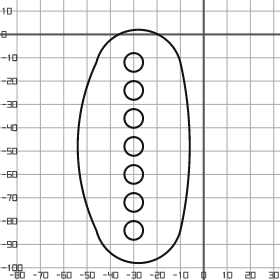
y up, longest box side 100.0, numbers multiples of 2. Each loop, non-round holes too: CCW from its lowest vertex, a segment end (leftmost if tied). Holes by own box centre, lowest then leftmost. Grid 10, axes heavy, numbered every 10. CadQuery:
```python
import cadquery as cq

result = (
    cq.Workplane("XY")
    .moveTo(-46.0, -84.0)
    .threePointArc((-28.0, -98.0), (-10.0, -84.0))
    .threePointArc((-6.0, -48.0), (-10.0, -12.0))
    .threePointArc((-28.0, 2.0), (-46.0, -12.0))
    .threePointArc((-54.0, -48.0), (-46.0, -84.0))
    .close()
    .moveTo(-30.0, -84.0)
    .circle(4.0)
    .moveTo(-30.0, -72.0)
    .circle(4.0)
    .moveTo(-30.0, -60.0)
    .circle(4.0)
    .moveTo(-30.0, -48.0)
    .circle(4.0)
    .moveTo(-30.0, -36.0)
    .circle(4.0)
    .moveTo(-30.0, -24.0)
    .circle(4.0)
    .moveTo(-30.0, -12.0)
    .circle(4.0)
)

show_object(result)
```